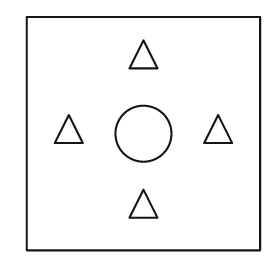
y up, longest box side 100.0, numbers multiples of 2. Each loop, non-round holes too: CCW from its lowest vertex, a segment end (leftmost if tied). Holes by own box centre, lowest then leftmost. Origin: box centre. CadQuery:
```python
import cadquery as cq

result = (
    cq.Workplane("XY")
    .moveTo(-50.0, -50.0)
    .lineTo(50.0, -50.0)
    .lineTo(50.0, 50.0)
    .lineTo(-50.0, 50.0)
    .close()
    .moveTo(-6.0, -36.0)
    .lineTo(6.0, -36.0)
    .lineTo(0.0, -24.0)
    .close()
    .moveTo(0.0, 0.0)
    .circle(12.0)
    .moveTo(-38.0, -4.0)
    .lineTo(-26.0, -4.0)
    .lineTo(-32.0, 8.0)
    .close()
    .moveTo(26.0, -4.0)
    .lineTo(38.0, -4.0)
    .lineTo(32.0, 8.0)
    .close()
    .moveTo(-6.0, 28.0)
    .lineTo(6.0, 28.0)
    .lineTo(0.0, 40.0)
    .close()
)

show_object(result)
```